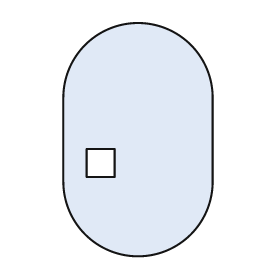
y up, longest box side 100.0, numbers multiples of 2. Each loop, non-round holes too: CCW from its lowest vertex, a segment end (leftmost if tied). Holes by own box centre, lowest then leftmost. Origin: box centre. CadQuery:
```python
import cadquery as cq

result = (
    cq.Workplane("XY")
    .moveTo(-32.0, -18.0)
    .threePointArc((0.0, -50.0), (32.0, -18.0))
    .lineTo(32.0, 18.0)
    .threePointArc((0.0, 50.0), (-32.0, 18.0))
    .close()
    .moveTo(-22.0, -16.0)
    .lineTo(-10.0, -16.0)
    .lineTo(-10.0, -4.0)
    .lineTo(-22.0, -4.0)
    .close()
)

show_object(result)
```